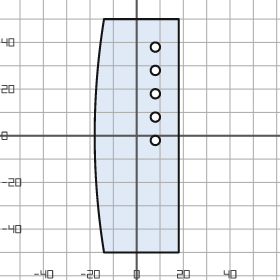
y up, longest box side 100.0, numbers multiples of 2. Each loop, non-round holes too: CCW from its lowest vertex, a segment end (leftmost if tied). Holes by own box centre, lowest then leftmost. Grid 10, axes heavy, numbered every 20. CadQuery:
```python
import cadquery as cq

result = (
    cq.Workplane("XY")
    .moveTo(-14.0, -50.0)
    .lineTo(18.0, -50.0)
    .lineTo(18.0, 50.0)
    .lineTo(-14.0, 50.0)
    .threePointArc((-18.0, 0.0), (-14.0, -50.0))
    .close()
    .moveTo(8.0, -2.0)
    .circle(2.0)
    .moveTo(8.0, 8.0)
    .circle(2.0)
    .moveTo(8.0, 18.0)
    .circle(2.0)
    .moveTo(8.0, 28.0)
    .circle(2.0)
    .moveTo(8.0, 38.0)
    .circle(2.0)
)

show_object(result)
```